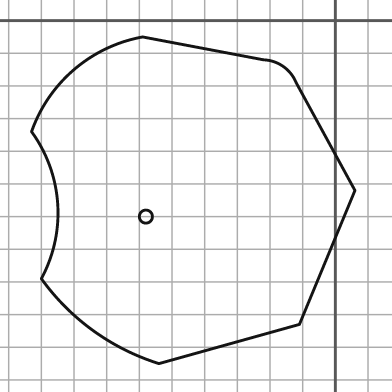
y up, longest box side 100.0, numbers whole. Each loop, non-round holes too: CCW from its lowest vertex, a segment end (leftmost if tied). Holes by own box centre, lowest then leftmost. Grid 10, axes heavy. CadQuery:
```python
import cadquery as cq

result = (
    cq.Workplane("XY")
    .moveTo(-54.0, -105.0)
    .lineTo(-11.0, -93.0)
    .lineTo(6.0, -52.0)
    .lineTo(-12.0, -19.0)
    .threePointArc((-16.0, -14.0), (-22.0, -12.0))
    .lineTo(-59.0, -5.0)
    .threePointArc((-80.0, -15.0), (-93.0, -34.0))
    .threePointArc((-85.0, -56.0), (-90.0, -79.0))
    .threePointArc((-74.0, -95.0), (-54.0, -105.0))
    .close()
    .moveTo(-58.0, -60.0)
    .circle(2.0)
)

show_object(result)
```